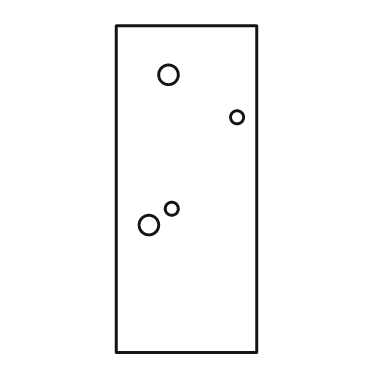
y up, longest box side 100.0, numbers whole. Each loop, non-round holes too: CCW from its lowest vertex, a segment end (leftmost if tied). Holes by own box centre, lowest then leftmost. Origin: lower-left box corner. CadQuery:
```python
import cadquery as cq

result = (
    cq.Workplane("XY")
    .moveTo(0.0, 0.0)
    .lineTo(43.0, 0.0)
    .lineTo(43.0, 100.0)
    .lineTo(0.0, 100.0)
    .close()
    .moveTo(10.0, 39.0)
    .circle(3.0)
    .moveTo(17.0, 44.0)
    .circle(2.0)
    .moveTo(37.0, 72.0)
    .circle(2.0)
    .moveTo(16.0, 85.0)
    .circle(3.0)
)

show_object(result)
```